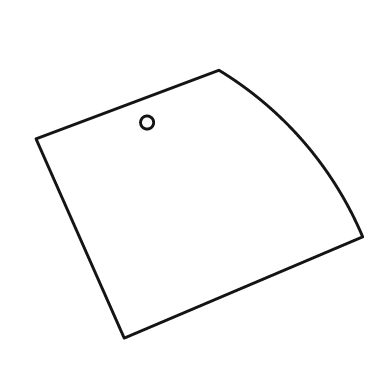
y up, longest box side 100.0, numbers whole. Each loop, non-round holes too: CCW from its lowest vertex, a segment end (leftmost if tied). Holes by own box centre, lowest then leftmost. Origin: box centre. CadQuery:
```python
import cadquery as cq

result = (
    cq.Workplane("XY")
    .moveTo(-23.0, -41.0)
    .lineTo(50.0, -10.0)
    .threePointArc((32.0, 19.0), (6.0, 41.0))
    .lineTo(-50.0, 20.0)
    .close()
    .moveTo(-16.0, 25.0)
    .circle(2.0)
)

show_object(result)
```